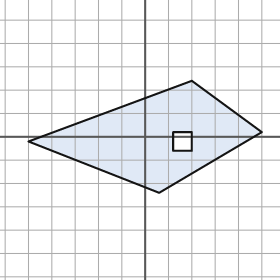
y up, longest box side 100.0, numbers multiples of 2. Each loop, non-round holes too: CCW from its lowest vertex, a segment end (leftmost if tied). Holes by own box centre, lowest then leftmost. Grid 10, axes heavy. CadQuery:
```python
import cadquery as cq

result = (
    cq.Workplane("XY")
    .moveTo(6.0, -24.0)
    .lineTo(50.0, 2.0)
    .lineTo(20.0, 24.0)
    .lineTo(-50.0, -2.0)
    .close()
    .moveTo(12.0, -6.0)
    .lineTo(20.0, -6.0)
    .lineTo(20.0, 2.0)
    .lineTo(12.0, 2.0)
    .close()
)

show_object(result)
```